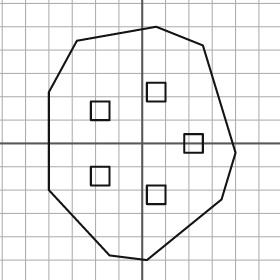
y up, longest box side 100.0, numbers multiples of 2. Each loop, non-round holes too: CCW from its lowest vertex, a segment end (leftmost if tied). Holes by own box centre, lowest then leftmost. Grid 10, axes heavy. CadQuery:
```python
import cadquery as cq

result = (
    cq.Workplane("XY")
    .moveTo(2.0, -50.0)
    .lineTo(34.0, -24.0)
    .lineTo(40.0, -4.0)
    .lineTo(26.0, 42.0)
    .lineTo(6.0, 50.0)
    .lineTo(-28.0, 44.0)
    .lineTo(-40.0, 22.0)
    .lineTo(-40.0, -20.0)
    .lineTo(-14.0, -48.0)
    .close()
    .moveTo(2.0, -26.0)
    .lineTo(10.0, -26.0)
    .lineTo(10.0, -18.0)
    .lineTo(2.0, -18.0)
    .close()
    .moveTo(-22.0, -18.0)
    .lineTo(-14.0, -18.0)
    .lineTo(-14.0, -10.0)
    .lineTo(-22.0, -10.0)
    .close()
    .moveTo(18.0, -4.0)
    .lineTo(26.0, -4.0)
    .lineTo(26.0, 4.0)
    .lineTo(18.0, 4.0)
    .close()
    .moveTo(-22.0, 10.0)
    .lineTo(-14.0, 10.0)
    .lineTo(-14.0, 18.0)
    .lineTo(-22.0, 18.0)
    .close()
    .moveTo(2.0, 18.0)
    .lineTo(10.0, 18.0)
    .lineTo(10.0, 26.0)
    .lineTo(2.0, 26.0)
    .close()
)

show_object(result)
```